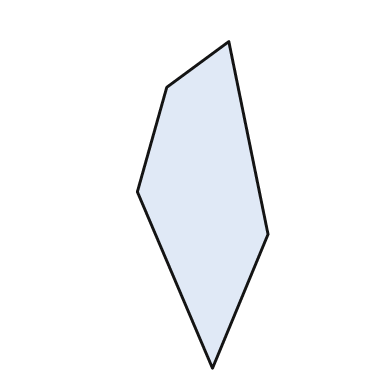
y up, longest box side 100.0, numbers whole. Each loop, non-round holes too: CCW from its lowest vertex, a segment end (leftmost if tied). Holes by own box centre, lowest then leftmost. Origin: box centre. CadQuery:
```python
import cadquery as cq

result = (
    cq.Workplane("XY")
    .moveTo(3.0, -50.0)
    .lineTo(20.0, -9.0)
    .lineTo(8.0, 50.0)
    .lineTo(-11.0, 36.0)
    .lineTo(-20.0, 4.0)
    .close()
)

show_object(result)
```